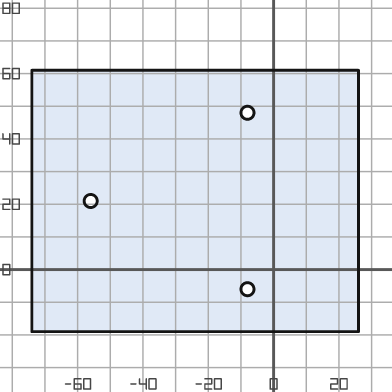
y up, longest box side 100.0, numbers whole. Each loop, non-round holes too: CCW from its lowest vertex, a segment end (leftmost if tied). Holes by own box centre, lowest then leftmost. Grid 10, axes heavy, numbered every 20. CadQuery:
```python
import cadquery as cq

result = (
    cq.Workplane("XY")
    .moveTo(-74.0, -19.0)
    .lineTo(26.0, -19.0)
    .lineTo(26.0, 61.0)
    .lineTo(-74.0, 61.0)
    .close()
    .moveTo(-8.0, -6.0)
    .circle(2.0)
    .moveTo(-56.0, 21.0)
    .circle(2.0)
    .moveTo(-8.0, 48.0)
    .circle(2.0)
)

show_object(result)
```